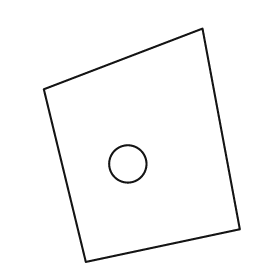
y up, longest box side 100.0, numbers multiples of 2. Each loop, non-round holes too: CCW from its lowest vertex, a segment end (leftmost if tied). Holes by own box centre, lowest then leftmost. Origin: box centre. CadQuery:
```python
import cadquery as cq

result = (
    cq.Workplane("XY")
    .moveTo(-24.0, -50.0)
    .lineTo(42.0, -36.0)
    .lineTo(26.0, 50.0)
    .lineTo(-42.0, 24.0)
    .close()
    .moveTo(-6.0, -8.0)
    .circle(8.0)
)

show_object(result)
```